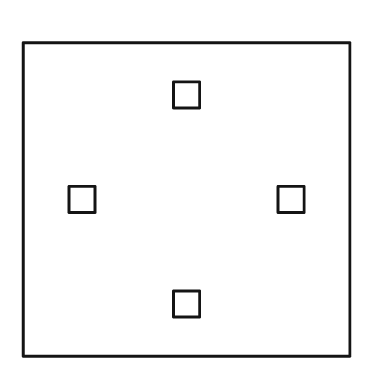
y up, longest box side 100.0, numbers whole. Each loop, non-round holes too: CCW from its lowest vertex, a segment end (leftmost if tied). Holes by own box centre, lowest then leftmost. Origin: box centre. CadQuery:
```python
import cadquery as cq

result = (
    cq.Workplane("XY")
    .moveTo(-50.0, -48.0)
    .lineTo(50.0, -48.0)
    .lineTo(50.0, 48.0)
    .lineTo(-50.0, 48.0)
    .close()
    .moveTo(-4.0, -36.0)
    .lineTo(4.0, -36.0)
    .lineTo(4.0, -28.0)
    .lineTo(-4.0, -28.0)
    .close()
    .moveTo(-36.0, -4.0)
    .lineTo(-28.0, -4.0)
    .lineTo(-28.0, 4.0)
    .lineTo(-36.0, 4.0)
    .close()
    .moveTo(28.0, -4.0)
    .lineTo(36.0, -4.0)
    .lineTo(36.0, 4.0)
    .lineTo(28.0, 4.0)
    .close()
    .moveTo(-4.0, 28.0)
    .lineTo(4.0, 28.0)
    .lineTo(4.0, 36.0)
    .lineTo(-4.0, 36.0)
    .close()
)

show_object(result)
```